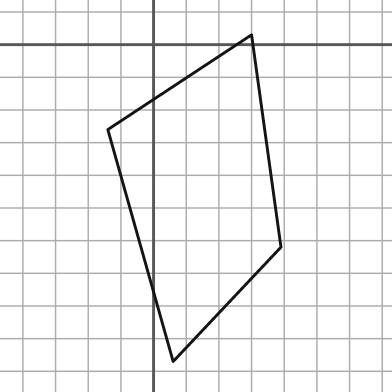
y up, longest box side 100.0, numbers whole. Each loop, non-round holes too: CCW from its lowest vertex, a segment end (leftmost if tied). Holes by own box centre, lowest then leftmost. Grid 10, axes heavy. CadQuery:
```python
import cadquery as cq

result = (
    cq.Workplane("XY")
    .moveTo(6.0, -97.0)
    .lineTo(39.0, -62.0)
    .lineTo(30.0, 3.0)
    .lineTo(-14.0, -26.0)
    .close()
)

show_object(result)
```